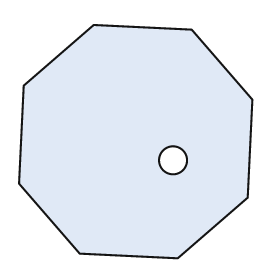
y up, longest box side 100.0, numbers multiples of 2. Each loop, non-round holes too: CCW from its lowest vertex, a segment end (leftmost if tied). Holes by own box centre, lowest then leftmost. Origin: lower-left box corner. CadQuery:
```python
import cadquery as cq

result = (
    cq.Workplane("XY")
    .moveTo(68.0, 0.0)
    .lineTo(98.0, 26.0)
    .lineTo(100.0, 68.0)
    .lineTo(74.0, 98.0)
    .lineTo(32.0, 100.0)
    .lineTo(2.0, 74.0)
    .lineTo(0.0, 32.0)
    .lineTo(26.0, 2.0)
    .close()
    .moveTo(66.0, 42.0)
    .circle(6.0)
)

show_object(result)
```